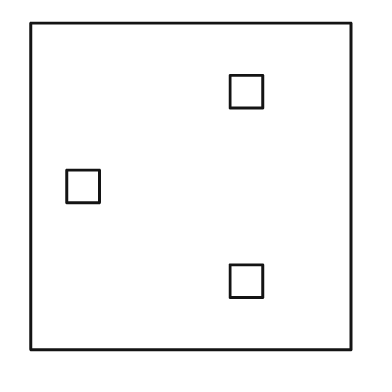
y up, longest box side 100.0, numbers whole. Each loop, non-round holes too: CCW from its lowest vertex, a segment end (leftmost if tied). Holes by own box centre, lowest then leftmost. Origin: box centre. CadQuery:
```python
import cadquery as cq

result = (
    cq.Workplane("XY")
    .moveTo(-49.0, -50.0)
    .lineTo(49.0, -50.0)
    .lineTo(49.0, 50.0)
    .lineTo(-49.0, 50.0)
    .close()
    .moveTo(12.0, -34.0)
    .lineTo(22.0, -34.0)
    .lineTo(22.0, -24.0)
    .lineTo(12.0, -24.0)
    .close()
    .moveTo(-38.0, -5.0)
    .lineTo(-28.0, -5.0)
    .lineTo(-28.0, 5.0)
    .lineTo(-38.0, 5.0)
    .close()
    .moveTo(12.0, 24.0)
    .lineTo(22.0, 24.0)
    .lineTo(22.0, 34.0)
    .lineTo(12.0, 34.0)
    .close()
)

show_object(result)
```